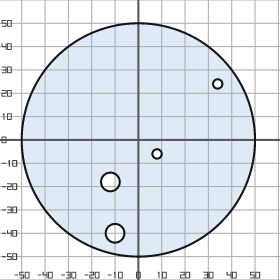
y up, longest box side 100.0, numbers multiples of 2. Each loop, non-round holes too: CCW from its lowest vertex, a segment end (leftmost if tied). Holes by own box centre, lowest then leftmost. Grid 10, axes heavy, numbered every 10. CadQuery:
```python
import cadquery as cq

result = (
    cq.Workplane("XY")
    .moveTo(0.0, 0.0)
    .circle(50.0)
    .moveTo(-10.0, -40.0)
    .circle(4.0)
    .moveTo(-12.0, -18.0)
    .circle(4.0)
    .moveTo(8.0, -6.0)
    .circle(2.0)
    .moveTo(34.0, 24.0)
    .circle(2.0)
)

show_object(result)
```